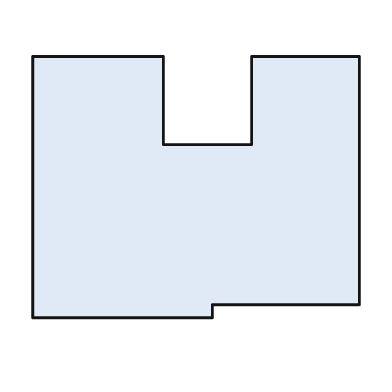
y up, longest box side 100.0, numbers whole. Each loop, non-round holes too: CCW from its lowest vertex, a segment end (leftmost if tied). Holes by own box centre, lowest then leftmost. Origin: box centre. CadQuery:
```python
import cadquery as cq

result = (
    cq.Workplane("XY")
    .moveTo(-50.0, -40.0)
    .lineTo(5.0, -40.0)
    .lineTo(5.0, -36.0)
    .lineTo(50.0, -36.0)
    .lineTo(50.0, 40.0)
    .lineTo(17.0, 40.0)
    .lineTo(17.0, 13.0)
    .lineTo(-10.0, 13.0)
    .lineTo(-10.0, 40.0)
    .lineTo(-50.0, 40.0)
    .close()
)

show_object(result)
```